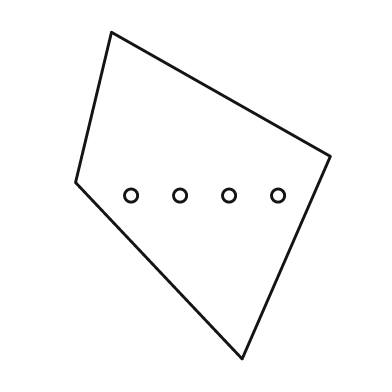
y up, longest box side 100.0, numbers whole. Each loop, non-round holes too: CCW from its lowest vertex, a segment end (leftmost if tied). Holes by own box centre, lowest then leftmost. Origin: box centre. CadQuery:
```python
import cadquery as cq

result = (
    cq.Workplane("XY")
    .moveTo(12.0, -50.0)
    .lineTo(39.0, 12.0)
    .lineTo(-28.0, 50.0)
    .lineTo(-39.0, 4.0)
    .close()
    .moveTo(-22.0, 0.0)
    .circle(2.0)
    .moveTo(-7.0, 0.0)
    .circle(2.0)
    .moveTo(8.0, 0.0)
    .circle(2.0)
    .moveTo(23.0, 0.0)
    .circle(2.0)
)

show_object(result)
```